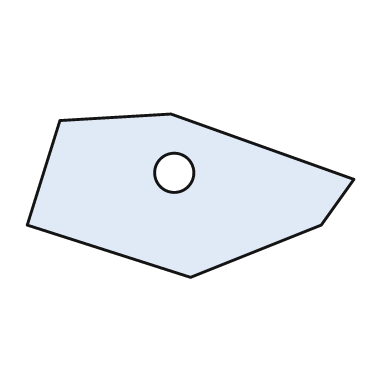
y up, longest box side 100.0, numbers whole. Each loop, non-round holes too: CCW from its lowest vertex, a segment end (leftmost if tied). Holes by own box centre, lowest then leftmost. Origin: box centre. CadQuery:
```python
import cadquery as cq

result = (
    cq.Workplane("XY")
    .moveTo(0.0, -25.0)
    .lineTo(40.0, -9.0)
    .lineTo(50.0, 5.0)
    .lineTo(-6.0, 25.0)
    .lineTo(-40.0, 23.0)
    .lineTo(-50.0, -9.0)
    .close()
    .moveTo(-5.0, 7.0)
    .circle(6.0)
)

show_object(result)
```